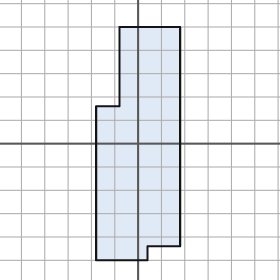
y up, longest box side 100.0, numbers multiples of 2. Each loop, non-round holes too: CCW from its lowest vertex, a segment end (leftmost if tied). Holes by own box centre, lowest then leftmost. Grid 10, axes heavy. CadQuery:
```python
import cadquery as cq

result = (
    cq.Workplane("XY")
    .moveTo(-18.0, -50.0)
    .lineTo(4.0, -50.0)
    .lineTo(4.0, -44.0)
    .lineTo(18.0, -44.0)
    .lineTo(18.0, 50.0)
    .lineTo(-8.0, 50.0)
    .lineTo(-8.0, 16.0)
    .lineTo(-18.0, 16.0)
    .close()
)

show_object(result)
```